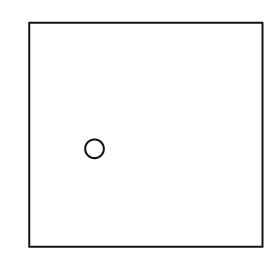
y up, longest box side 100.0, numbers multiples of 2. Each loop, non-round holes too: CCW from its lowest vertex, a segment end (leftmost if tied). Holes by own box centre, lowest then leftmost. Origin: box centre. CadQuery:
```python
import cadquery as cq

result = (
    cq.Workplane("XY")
    .moveTo(-50.0, -48.0)
    .lineTo(50.0, -48.0)
    .lineTo(50.0, 48.0)
    .lineTo(-50.0, 48.0)
    .close()
    .moveTo(-22.0, -6.0)
    .circle(4.0)
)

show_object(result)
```